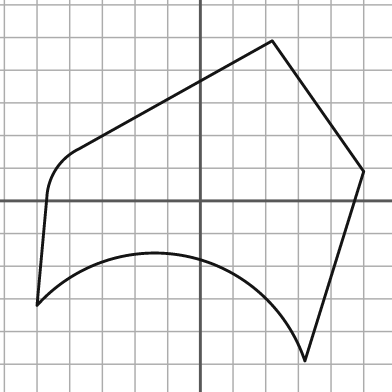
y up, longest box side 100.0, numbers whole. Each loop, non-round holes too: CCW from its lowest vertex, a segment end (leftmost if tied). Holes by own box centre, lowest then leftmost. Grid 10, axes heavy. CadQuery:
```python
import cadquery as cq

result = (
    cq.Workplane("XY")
    .moveTo(32.0, -49.0)
    .lineTo(50.0, 9.0)
    .lineTo(22.0, 49.0)
    .lineTo(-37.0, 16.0)
    .threePointArc((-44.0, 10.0), (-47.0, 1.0))
    .lineTo(-50.0, -32.0)
    .threePointArc((-4.0, -17.0), (32.0, -49.0))
    .close()
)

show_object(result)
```